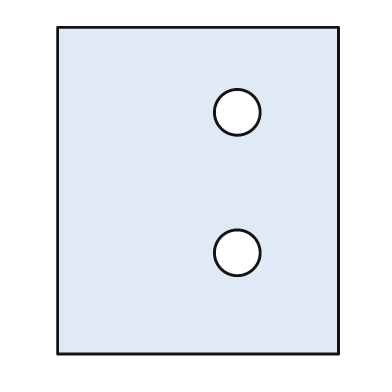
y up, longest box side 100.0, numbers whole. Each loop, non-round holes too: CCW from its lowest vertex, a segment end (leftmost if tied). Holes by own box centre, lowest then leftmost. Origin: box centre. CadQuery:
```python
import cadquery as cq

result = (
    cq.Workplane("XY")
    .moveTo(-43.0, -50.0)
    .lineTo(43.0, -50.0)
    .lineTo(43.0, 50.0)
    .lineTo(-43.0, 50.0)
    .close()
    .moveTo(12.0, -19.0)
    .circle(7.0)
    .moveTo(12.0, 24.0)
    .circle(7.0)
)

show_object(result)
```